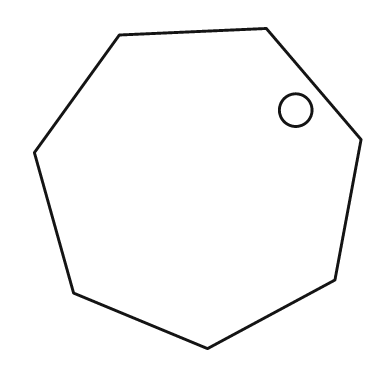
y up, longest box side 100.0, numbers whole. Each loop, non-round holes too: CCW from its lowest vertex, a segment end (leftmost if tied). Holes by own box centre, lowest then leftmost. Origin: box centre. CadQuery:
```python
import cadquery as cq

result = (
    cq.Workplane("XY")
    .moveTo(3.0, -49.0)
    .lineTo(42.0, -28.0)
    .lineTo(50.0, 15.0)
    .lineTo(21.0, 49.0)
    .lineTo(-24.0, 47.0)
    .lineTo(-50.0, 11.0)
    .lineTo(-38.0, -32.0)
    .close()
    .moveTo(30.0, 24.0)
    .circle(5.0)
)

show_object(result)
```